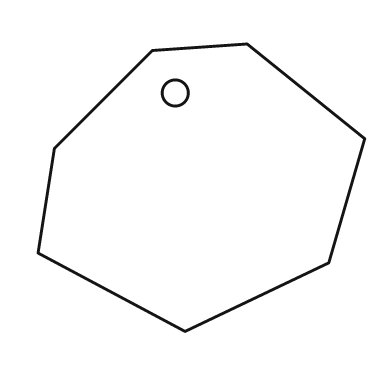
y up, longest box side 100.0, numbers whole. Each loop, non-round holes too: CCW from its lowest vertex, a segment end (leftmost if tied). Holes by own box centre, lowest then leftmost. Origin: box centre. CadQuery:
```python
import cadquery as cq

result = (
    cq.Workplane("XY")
    .moveTo(-5.0, -44.0)
    .lineTo(39.0, -23.0)
    .lineTo(50.0, 15.0)
    .lineTo(14.0, 44.0)
    .lineTo(-15.0, 42.0)
    .lineTo(-45.0, 12.0)
    .lineTo(-50.0, -20.0)
    .close()
    .moveTo(-8.0, 29.0)
    .circle(4.0)
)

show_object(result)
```